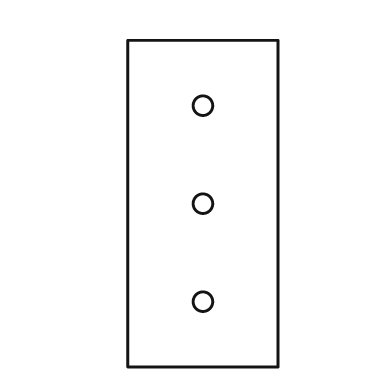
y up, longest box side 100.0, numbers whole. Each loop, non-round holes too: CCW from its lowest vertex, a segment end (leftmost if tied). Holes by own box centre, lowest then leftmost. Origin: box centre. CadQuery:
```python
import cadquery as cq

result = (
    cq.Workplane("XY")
    .moveTo(-23.0, -50.0)
    .lineTo(23.0, -50.0)
    .lineTo(23.0, 50.0)
    .lineTo(-23.0, 50.0)
    .close()
    .moveTo(0.0, -30.0)
    .circle(3.0)
    .moveTo(0.0, 0.0)
    .circle(3.0)
    .moveTo(0.0, 30.0)
    .circle(3.0)
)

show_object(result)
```